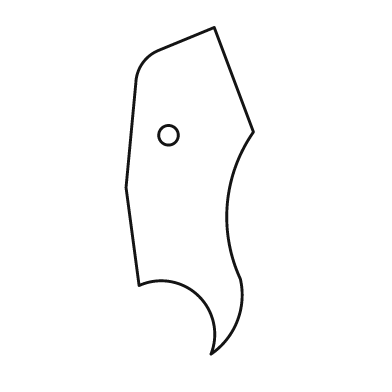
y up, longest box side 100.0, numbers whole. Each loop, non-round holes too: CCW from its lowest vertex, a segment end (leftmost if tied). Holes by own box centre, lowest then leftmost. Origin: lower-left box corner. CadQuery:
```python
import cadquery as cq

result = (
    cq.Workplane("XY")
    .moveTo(26.0, 0.0)
    .threePointArc((34.0, 10.0), (35.0, 23.0))
    .threePointArc((31.0, 46.0), (39.0, 68.0))
    .lineTo(27.0, 100.0)
    .lineTo(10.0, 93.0)
    .threePointArc((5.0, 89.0), (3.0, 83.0))
    .lineTo(0.0, 51.0)
    .lineTo(4.0, 21.0)
    .threePointArc((22.0, 18.0), (26.0, 0.0))
    .close()
    .moveTo(13.0, 67.0)
    .circle(3.0)
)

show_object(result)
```